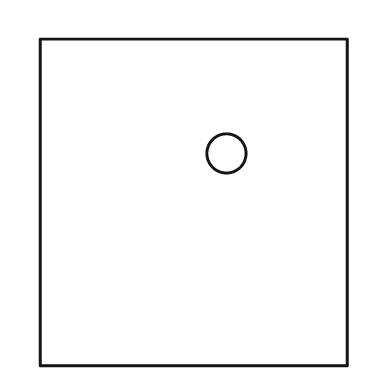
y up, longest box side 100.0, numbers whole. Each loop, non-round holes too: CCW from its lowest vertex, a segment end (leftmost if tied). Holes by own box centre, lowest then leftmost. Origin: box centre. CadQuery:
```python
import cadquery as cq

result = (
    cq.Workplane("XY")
    .moveTo(-47.0, -50.0)
    .lineTo(47.0, -50.0)
    .lineTo(47.0, 50.0)
    .lineTo(-47.0, 50.0)
    .close()
    .moveTo(10.0, 15.0)
    .circle(6.0)
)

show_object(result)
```